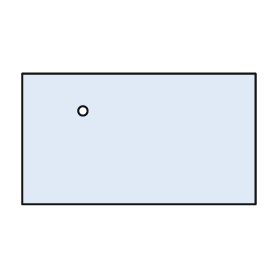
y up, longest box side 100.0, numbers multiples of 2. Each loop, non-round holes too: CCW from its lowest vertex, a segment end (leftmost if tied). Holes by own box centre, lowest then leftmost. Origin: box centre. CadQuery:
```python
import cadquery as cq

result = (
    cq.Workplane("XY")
    .moveTo(-50.0, -28.0)
    .lineTo(50.0, -28.0)
    .lineTo(50.0, 28.0)
    .lineTo(-50.0, 28.0)
    .close()
    .moveTo(-24.0, 12.0)
    .circle(2.0)
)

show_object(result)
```